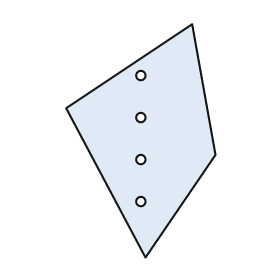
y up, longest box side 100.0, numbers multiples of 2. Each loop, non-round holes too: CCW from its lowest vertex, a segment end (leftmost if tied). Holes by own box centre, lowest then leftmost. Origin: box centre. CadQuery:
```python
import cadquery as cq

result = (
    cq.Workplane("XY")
    .moveTo(2.0, -50.0)
    .lineTo(32.0, -6.0)
    .lineTo(22.0, 50.0)
    .lineTo(-32.0, 14.0)
    .close()
    .moveTo(0.0, -26.0)
    .circle(2.0)
    .moveTo(0.0, -8.0)
    .circle(2.0)
    .moveTo(0.0, 10.0)
    .circle(2.0)
    .moveTo(0.0, 28.0)
    .circle(2.0)
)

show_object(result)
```